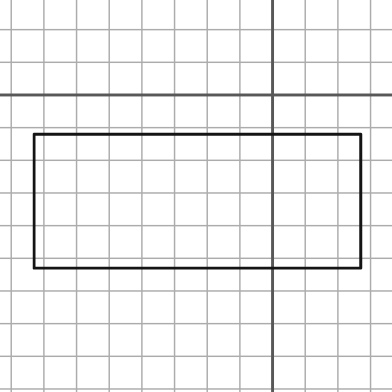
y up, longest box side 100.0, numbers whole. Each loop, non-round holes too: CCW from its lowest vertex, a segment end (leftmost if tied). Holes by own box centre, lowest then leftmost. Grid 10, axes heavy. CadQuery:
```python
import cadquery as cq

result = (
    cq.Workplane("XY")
    .moveTo(-73.0, -53.0)
    .lineTo(27.0, -53.0)
    .lineTo(27.0, -12.0)
    .lineTo(-73.0, -12.0)
    .close()
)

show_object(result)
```